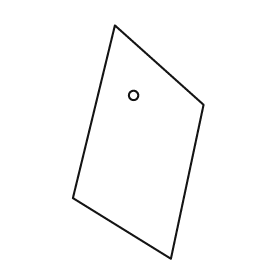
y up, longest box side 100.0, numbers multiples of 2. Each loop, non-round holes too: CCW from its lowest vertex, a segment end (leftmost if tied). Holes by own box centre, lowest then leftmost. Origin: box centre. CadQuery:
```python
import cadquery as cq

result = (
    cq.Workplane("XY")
    .moveTo(14.0, -50.0)
    .lineTo(28.0, 16.0)
    .lineTo(-10.0, 50.0)
    .lineTo(-28.0, -24.0)
    .close()
    .moveTo(-2.0, 20.0)
    .circle(2.0)
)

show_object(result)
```